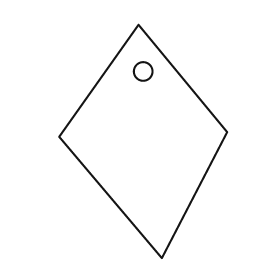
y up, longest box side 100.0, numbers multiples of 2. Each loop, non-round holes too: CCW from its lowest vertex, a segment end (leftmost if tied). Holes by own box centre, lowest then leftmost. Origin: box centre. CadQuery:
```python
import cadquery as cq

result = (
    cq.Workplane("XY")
    .moveTo(8.0, -50.0)
    .lineTo(36.0, 4.0)
    .lineTo(-2.0, 50.0)
    .lineTo(-36.0, 2.0)
    .close()
    .moveTo(0.0, 30.0)
    .circle(4.0)
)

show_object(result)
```